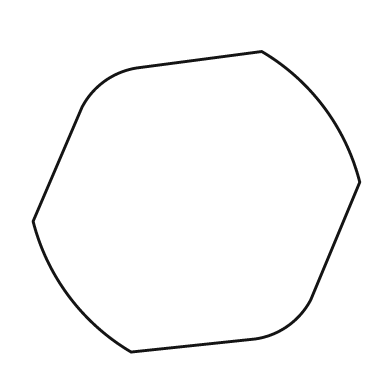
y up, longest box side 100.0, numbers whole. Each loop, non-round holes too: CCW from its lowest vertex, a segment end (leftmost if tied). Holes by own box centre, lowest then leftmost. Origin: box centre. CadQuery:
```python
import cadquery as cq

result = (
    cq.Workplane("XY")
    .moveTo(-20.0, -46.0)
    .lineTo(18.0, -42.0)
    .threePointArc((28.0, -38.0), (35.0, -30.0))
    .lineTo(50.0, 6.0)
    .threePointArc((39.0, 29.0), (20.0, 46.0))
    .lineTo(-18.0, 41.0)
    .threePointArc((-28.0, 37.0), (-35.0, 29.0))
    .lineTo(-50.0, -6.0)
    .threePointArc((-39.0, -29.0), (-20.0, -46.0))
    .close()
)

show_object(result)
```